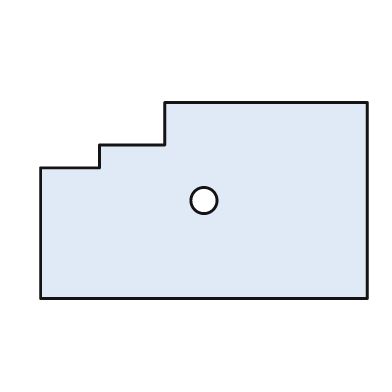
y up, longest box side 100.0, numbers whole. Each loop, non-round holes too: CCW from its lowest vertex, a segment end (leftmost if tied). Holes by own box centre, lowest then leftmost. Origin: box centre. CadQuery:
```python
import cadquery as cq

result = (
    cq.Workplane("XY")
    .moveTo(-50.0, -30.0)
    .lineTo(50.0, -30.0)
    .lineTo(50.0, 30.0)
    .lineTo(-12.0, 30.0)
    .lineTo(-12.0, 17.0)
    .lineTo(-32.0, 17.0)
    .lineTo(-32.0, 10.0)
    .lineTo(-50.0, 10.0)
    .close()
    .moveTo(0.0, 0.0)
    .circle(4.0)
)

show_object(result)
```